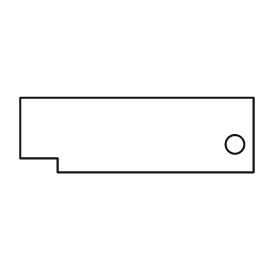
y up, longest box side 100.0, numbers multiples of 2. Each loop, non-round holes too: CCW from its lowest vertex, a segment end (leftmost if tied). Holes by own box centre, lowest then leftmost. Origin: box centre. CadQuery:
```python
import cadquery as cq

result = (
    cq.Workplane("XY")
    .moveTo(-34.0, -16.0)
    .lineTo(50.0, -16.0)
    .lineTo(50.0, 16.0)
    .lineTo(-50.0, 16.0)
    .lineTo(-50.0, -10.0)
    .lineTo(-34.0, -10.0)
    .close()
    .moveTo(42.0, -4.0)
    .circle(4.0)
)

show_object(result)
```